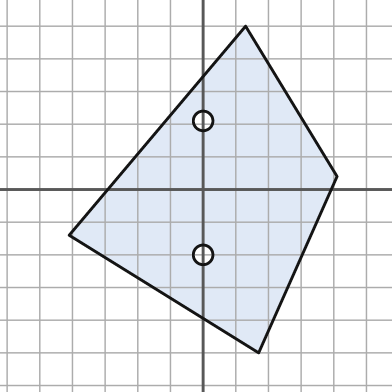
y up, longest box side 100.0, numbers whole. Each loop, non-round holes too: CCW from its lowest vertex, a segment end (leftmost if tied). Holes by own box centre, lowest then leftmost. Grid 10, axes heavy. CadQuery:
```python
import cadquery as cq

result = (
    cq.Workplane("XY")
    .moveTo(17.0, -50.0)
    .lineTo(41.0, 4.0)
    .lineTo(13.0, 50.0)
    .lineTo(-41.0, -14.0)
    .close()
    .moveTo(0.0, -20.0)
    .circle(3.0)
    .moveTo(0.0, 21.0)
    .circle(3.0)
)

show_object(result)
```